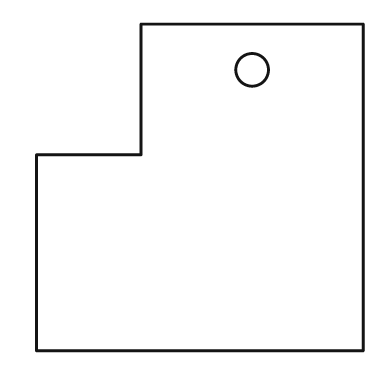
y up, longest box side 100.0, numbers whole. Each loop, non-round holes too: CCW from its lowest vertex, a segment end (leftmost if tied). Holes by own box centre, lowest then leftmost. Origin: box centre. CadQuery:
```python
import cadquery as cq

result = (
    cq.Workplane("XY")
    .moveTo(-50.0, -50.0)
    .lineTo(50.0, -50.0)
    .lineTo(50.0, 50.0)
    .lineTo(-18.0, 50.0)
    .lineTo(-18.0, 10.0)
    .lineTo(-50.0, 10.0)
    .close()
    .moveTo(16.0, 36.0)
    .circle(5.0)
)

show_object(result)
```